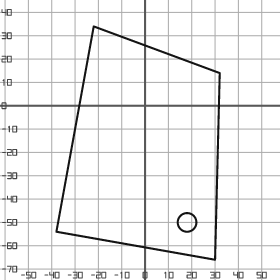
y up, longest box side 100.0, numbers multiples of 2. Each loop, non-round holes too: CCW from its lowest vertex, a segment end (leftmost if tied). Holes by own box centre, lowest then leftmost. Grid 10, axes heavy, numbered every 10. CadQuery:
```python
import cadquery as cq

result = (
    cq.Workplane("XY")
    .moveTo(30.0, -66.0)
    .lineTo(32.0, 14.0)
    .lineTo(-22.0, 34.0)
    .lineTo(-38.0, -54.0)
    .close()
    .moveTo(18.0, -50.0)
    .circle(4.0)
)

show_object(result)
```